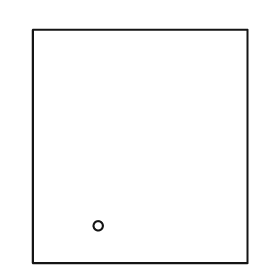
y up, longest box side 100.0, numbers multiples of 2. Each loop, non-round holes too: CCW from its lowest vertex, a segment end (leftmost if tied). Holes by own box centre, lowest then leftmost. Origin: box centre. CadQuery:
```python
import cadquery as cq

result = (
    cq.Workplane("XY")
    .moveTo(-46.0, -50.0)
    .lineTo(46.0, -50.0)
    .lineTo(46.0, 50.0)
    .lineTo(-46.0, 50.0)
    .close()
    .moveTo(-18.0, -34.0)
    .circle(2.0)
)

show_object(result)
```